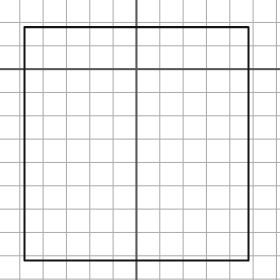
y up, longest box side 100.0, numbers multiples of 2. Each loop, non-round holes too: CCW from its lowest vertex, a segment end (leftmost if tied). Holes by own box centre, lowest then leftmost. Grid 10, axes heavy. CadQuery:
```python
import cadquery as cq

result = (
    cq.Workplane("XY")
    .moveTo(-48.0, -82.0)
    .lineTo(48.0, -82.0)
    .lineTo(48.0, 18.0)
    .lineTo(-48.0, 18.0)
    .close()
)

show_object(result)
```